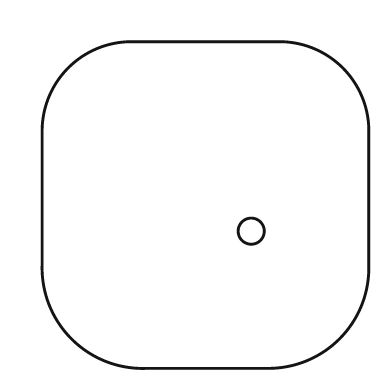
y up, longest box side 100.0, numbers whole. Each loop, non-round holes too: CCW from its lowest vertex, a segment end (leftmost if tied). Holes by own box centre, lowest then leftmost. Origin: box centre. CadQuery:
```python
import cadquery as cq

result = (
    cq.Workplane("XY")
    .moveTo(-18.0, -50.0)
    .lineTo(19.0, -50.0)
    .threePointArc((41.0, -41.0), (50.0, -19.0))
    .lineTo(50.0, 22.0)
    .threePointArc((42.0, 42.0), (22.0, 50.0))
    .lineTo(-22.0, 50.0)
    .threePointArc((-42.0, 42.0), (-50.0, 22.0))
    .lineTo(-50.0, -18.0)
    .threePointArc((-41.0, -41.0), (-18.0, -50.0))
    .close()
    .moveTo(14.0, -8.0)
    .circle(4.0)
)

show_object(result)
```